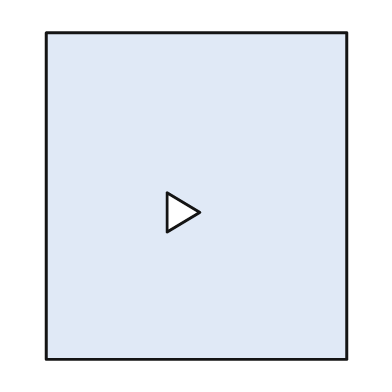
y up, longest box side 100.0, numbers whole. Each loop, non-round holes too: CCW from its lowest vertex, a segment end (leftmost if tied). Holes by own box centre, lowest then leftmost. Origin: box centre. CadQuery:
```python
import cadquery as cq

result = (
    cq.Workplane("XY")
    .moveTo(-46.0, -50.0)
    .lineTo(46.0, -50.0)
    .lineTo(46.0, 50.0)
    .lineTo(-46.0, 50.0)
    .close()
    .moveTo(-9.0, -11.0)
    .lineTo(1.0, -5.0)
    .lineTo(-9.0, 1.0)
    .close()
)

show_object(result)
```